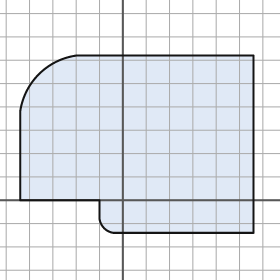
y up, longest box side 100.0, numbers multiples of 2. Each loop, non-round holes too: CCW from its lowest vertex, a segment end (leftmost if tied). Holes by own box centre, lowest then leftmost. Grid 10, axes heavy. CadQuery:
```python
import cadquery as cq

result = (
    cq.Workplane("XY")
    .moveTo(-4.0, -14.0)
    .lineTo(56.0, -14.0)
    .lineTo(56.0, 62.0)
    .lineTo(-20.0, 62.0)
    .threePointArc((-36.0, 54.0), (-44.0, 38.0))
    .lineTo(-44.0, 0.0)
    .lineTo(-10.0, 0.0)
    .lineTo(-10.0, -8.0)
    .threePointArc((-8.0, -12.0), (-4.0, -14.0))
    .close()
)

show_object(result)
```